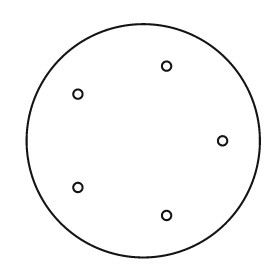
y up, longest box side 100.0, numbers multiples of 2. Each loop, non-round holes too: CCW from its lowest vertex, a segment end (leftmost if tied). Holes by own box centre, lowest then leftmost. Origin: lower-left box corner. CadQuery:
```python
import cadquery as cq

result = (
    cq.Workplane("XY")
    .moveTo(50.0, 50.0)
    .circle(50.0)
    .moveTo(60.0, 18.0)
    .circle(2.0)
    .moveTo(22.0, 30.0)
    .circle(2.0)
    .moveTo(84.0, 50.0)
    .circle(2.0)
    .moveTo(22.0, 70.0)
    .circle(2.0)
    .moveTo(60.0, 82.0)
    .circle(2.0)
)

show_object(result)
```